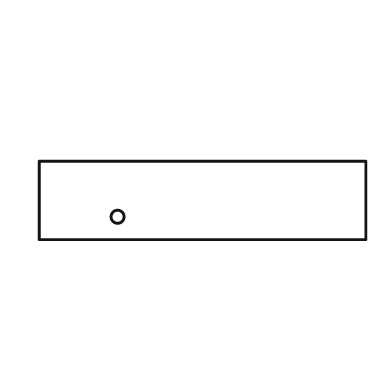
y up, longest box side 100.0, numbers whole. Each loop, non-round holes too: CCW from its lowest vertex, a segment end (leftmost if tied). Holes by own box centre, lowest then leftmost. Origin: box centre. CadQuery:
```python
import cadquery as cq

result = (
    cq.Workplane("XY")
    .moveTo(-50.0, -12.0)
    .lineTo(50.0, -12.0)
    .lineTo(50.0, 12.0)
    .lineTo(-50.0, 12.0)
    .close()
    .moveTo(-26.0, -5.0)
    .circle(2.0)
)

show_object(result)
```